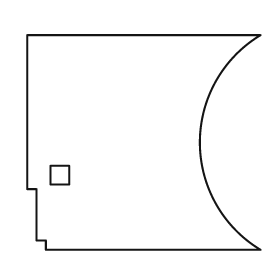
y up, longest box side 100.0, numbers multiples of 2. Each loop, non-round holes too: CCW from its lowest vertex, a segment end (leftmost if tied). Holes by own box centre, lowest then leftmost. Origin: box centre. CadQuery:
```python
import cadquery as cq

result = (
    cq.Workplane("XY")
    .moveTo(-42.0, -46.0)
    .lineTo(50.0, -46.0)
    .threePointArc((24.0, 0.0), (50.0, 46.0))
    .lineTo(-50.0, 46.0)
    .lineTo(-50.0, -20.0)
    .lineTo(-46.0, -20.0)
    .lineTo(-46.0, -42.0)
    .lineTo(-42.0, -42.0)
    .close()
    .moveTo(-40.0, -18.0)
    .lineTo(-32.0, -18.0)
    .lineTo(-32.0, -10.0)
    .lineTo(-40.0, -10.0)
    .close()
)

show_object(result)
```